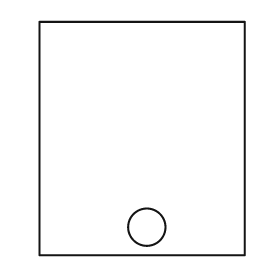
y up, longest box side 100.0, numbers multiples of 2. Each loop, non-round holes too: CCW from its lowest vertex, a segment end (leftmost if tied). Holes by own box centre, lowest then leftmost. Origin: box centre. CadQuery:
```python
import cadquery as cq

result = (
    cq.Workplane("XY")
    .moveTo(-44.0, -50.0)
    .lineTo(44.0, -50.0)
    .lineTo(44.0, 50.0)
    .lineTo(-44.0, 50.0)
    .close()
    .moveTo(2.0, -38.0)
    .circle(8.0)
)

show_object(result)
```